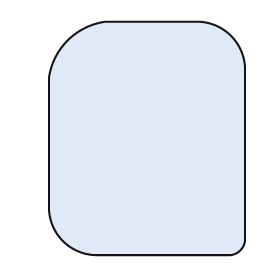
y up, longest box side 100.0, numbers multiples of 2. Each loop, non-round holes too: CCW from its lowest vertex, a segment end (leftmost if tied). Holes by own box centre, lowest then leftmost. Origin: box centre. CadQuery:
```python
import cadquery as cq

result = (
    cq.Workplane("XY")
    .moveTo(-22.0, -50.0)
    .lineTo(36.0, -50.0)
    .threePointArc((40.0, -48.0), (42.0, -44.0))
    .lineTo(42.0, 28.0)
    .threePointArc((36.0, 44.0), (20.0, 50.0))
    .lineTo(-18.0, 50.0)
    .threePointArc((-34.0, 42.0), (-42.0, 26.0))
    .lineTo(-42.0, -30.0)
    .threePointArc((-36.0, -44.0), (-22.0, -50.0))
    .close()
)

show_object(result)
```